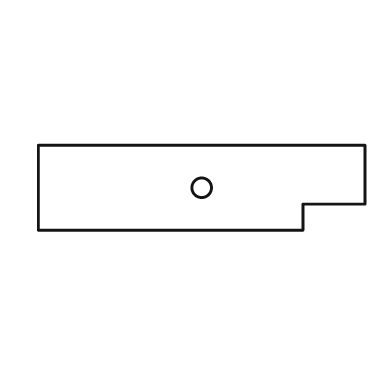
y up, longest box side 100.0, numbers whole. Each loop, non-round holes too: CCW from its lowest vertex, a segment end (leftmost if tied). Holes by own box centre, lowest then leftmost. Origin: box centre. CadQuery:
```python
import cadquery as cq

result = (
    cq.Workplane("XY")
    .moveTo(-50.0, -13.0)
    .lineTo(31.0, -13.0)
    .lineTo(31.0, -5.0)
    .lineTo(50.0, -5.0)
    .lineTo(50.0, 13.0)
    .lineTo(-50.0, 13.0)
    .close()
    .moveTo(0.0, 0.0)
    .circle(3.0)
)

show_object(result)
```